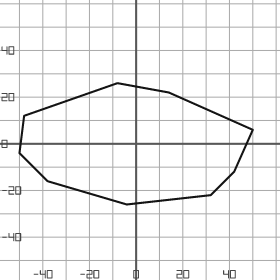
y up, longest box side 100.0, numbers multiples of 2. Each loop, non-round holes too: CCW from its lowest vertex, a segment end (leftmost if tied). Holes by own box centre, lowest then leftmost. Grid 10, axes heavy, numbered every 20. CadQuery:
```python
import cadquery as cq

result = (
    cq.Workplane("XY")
    .moveTo(-4.0, -26.0)
    .lineTo(32.0, -22.0)
    .lineTo(42.0, -12.0)
    .lineTo(50.0, 6.0)
    .lineTo(14.0, 22.0)
    .lineTo(-8.0, 26.0)
    .lineTo(-48.0, 12.0)
    .lineTo(-50.0, -4.0)
    .lineTo(-38.0, -16.0)
    .close()
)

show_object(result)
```